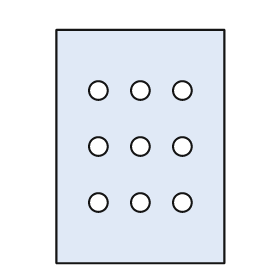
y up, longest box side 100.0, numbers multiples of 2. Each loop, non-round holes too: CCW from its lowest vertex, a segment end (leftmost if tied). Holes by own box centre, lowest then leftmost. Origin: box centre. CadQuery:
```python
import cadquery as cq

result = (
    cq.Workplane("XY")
    .moveTo(-36.0, -50.0)
    .lineTo(36.0, -50.0)
    .lineTo(36.0, 50.0)
    .lineTo(-36.0, 50.0)
    .close()
    .moveTo(-18.0, -24.0)
    .circle(4.0)
    .moveTo(0.0, -24.0)
    .circle(4.0)
    .moveTo(18.0, -24.0)
    .circle(4.0)
    .moveTo(-18.0, 0.0)
    .circle(4.0)
    .moveTo(0.0, 0.0)
    .circle(4.0)
    .moveTo(18.0, 0.0)
    .circle(4.0)
    .moveTo(-18.0, 24.0)
    .circle(4.0)
    .moveTo(0.0, 24.0)
    .circle(4.0)
    .moveTo(18.0, 24.0)
    .circle(4.0)
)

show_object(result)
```